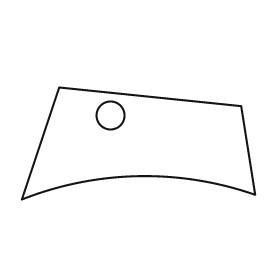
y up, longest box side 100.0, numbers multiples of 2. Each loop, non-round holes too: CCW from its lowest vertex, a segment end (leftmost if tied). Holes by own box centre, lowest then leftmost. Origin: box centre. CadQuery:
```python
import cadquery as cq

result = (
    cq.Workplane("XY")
    .moveTo(-50.0, -24.0)
    .threePointArc((0.0, -14.0), (50.0, -22.0))
    .lineTo(44.0, 16.0)
    .lineTo(-34.0, 24.0)
    .close()
    .moveTo(-12.0, 12.0)
    .circle(6.0)
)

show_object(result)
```